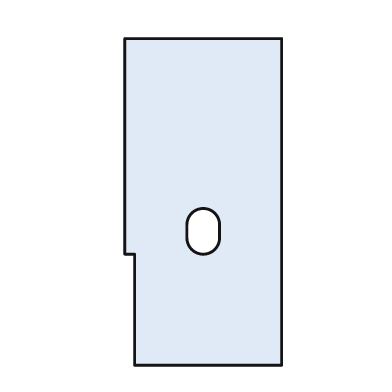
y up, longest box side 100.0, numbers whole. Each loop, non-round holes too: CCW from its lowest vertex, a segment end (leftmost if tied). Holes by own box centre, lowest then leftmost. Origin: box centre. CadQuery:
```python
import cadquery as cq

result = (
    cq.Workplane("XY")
    .moveTo(-21.0, -50.0)
    .lineTo(24.0, -50.0)
    .lineTo(24.0, 50.0)
    .lineTo(-24.0, 50.0)
    .lineTo(-24.0, -16.0)
    .lineTo(-21.0, -16.0)
    .close()
    .moveTo(-5.0, -11.0)
    .threePointArc((0.0, -16.0), (5.0, -11.0))
    .lineTo(5.0, -7.0)
    .threePointArc((0.0, -2.0), (-5.0, -7.0))
    .close()
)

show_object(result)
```